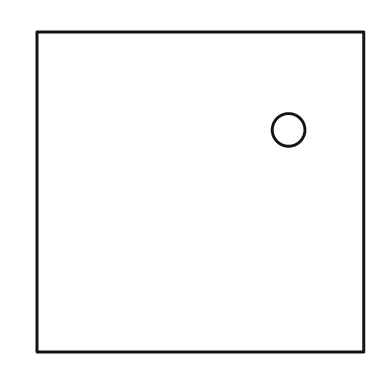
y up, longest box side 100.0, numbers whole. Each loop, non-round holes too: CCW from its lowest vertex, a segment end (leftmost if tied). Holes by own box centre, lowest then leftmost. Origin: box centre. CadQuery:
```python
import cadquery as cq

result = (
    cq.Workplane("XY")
    .moveTo(-50.0, -49.0)
    .lineTo(50.0, -49.0)
    .lineTo(50.0, 49.0)
    .lineTo(-50.0, 49.0)
    .close()
    .moveTo(27.0, 19.0)
    .circle(5.0)
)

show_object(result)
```